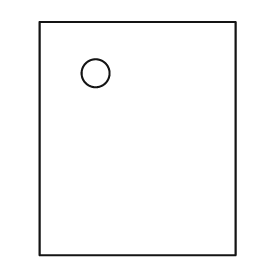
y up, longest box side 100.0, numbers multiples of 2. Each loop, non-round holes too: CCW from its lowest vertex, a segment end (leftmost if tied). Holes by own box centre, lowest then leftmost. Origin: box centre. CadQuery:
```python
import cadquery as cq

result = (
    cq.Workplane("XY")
    .moveTo(-42.0, -50.0)
    .lineTo(42.0, -50.0)
    .lineTo(42.0, 50.0)
    .lineTo(-42.0, 50.0)
    .close()
    .moveTo(-18.0, 28.0)
    .circle(6.0)
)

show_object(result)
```